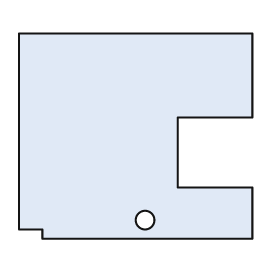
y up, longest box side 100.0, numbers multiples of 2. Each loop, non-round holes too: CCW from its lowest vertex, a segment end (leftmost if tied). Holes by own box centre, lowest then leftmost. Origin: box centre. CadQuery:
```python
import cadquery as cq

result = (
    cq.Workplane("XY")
    .moveTo(-40.0, -44.0)
    .lineTo(50.0, -44.0)
    .lineTo(50.0, -22.0)
    .lineTo(18.0, -22.0)
    .lineTo(18.0, 8.0)
    .lineTo(50.0, 8.0)
    .lineTo(50.0, 44.0)
    .lineTo(-50.0, 44.0)
    .lineTo(-50.0, -40.0)
    .lineTo(-40.0, -40.0)
    .close()
    .moveTo(4.0, -36.0)
    .circle(4.0)
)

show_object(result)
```